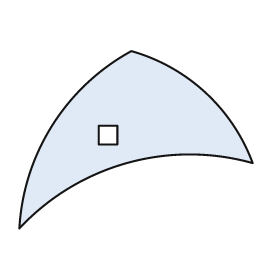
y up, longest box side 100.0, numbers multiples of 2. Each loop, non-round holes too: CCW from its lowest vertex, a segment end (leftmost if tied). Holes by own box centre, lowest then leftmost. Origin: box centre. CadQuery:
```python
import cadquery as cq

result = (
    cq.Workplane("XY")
    .moveTo(-50.0, -38.0)
    .threePointArc((-4.0, -10.0), (50.0, -10.0))
    .threePointArc((30.0, 20.0), (-2.0, 38.0))
    .threePointArc((-36.0, 6.0), (-50.0, -38.0))
    .close()
    .moveTo(-16.0, -2.0)
    .lineTo(-8.0, -2.0)
    .lineTo(-8.0, 6.0)
    .lineTo(-16.0, 6.0)
    .close()
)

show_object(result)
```